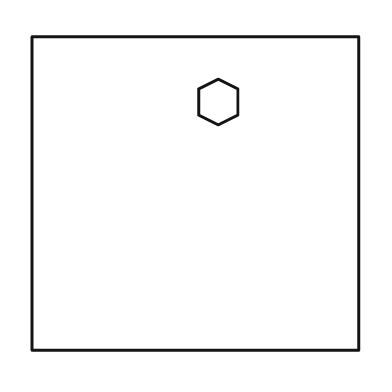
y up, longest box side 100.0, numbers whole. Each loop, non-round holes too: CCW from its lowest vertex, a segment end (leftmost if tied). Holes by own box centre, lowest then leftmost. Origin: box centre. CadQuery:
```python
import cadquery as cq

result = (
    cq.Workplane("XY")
    .moveTo(-50.0, -48.0)
    .lineTo(50.0, -48.0)
    .lineTo(50.0, 48.0)
    .lineTo(-50.0, 48.0)
    .close()
    .moveTo(7.0, 21.0)
    .lineTo(13.0, 24.0)
    .lineTo(13.0, 32.0)
    .lineTo(7.0, 35.0)
    .lineTo(1.0, 32.0)
    .lineTo(1.0, 24.0)
    .close()
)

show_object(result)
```